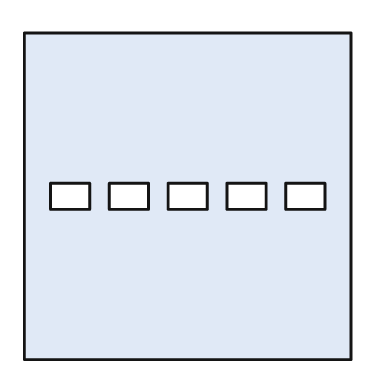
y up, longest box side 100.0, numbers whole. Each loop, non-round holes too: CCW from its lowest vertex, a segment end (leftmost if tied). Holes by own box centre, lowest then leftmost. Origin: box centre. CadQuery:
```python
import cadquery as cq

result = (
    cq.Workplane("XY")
    .moveTo(-50.0, -50.0)
    .lineTo(50.0, -50.0)
    .lineTo(50.0, 50.0)
    .lineTo(-50.0, 50.0)
    .close()
    .moveTo(-42.0, -4.0)
    .lineTo(-30.0, -4.0)
    .lineTo(-30.0, 4.0)
    .lineTo(-42.0, 4.0)
    .close()
    .moveTo(-24.0, -4.0)
    .lineTo(-12.0, -4.0)
    .lineTo(-12.0, 4.0)
    .lineTo(-24.0, 4.0)
    .close()
    .moveTo(-6.0, -4.0)
    .lineTo(6.0, -4.0)
    .lineTo(6.0, 4.0)
    .lineTo(-6.0, 4.0)
    .close()
    .moveTo(12.0, -4.0)
    .lineTo(24.0, -4.0)
    .lineTo(24.0, 4.0)
    .lineTo(12.0, 4.0)
    .close()
    .moveTo(30.0, -4.0)
    .lineTo(42.0, -4.0)
    .lineTo(42.0, 4.0)
    .lineTo(30.0, 4.0)
    .close()
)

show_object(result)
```